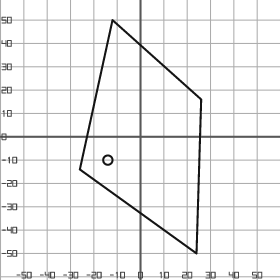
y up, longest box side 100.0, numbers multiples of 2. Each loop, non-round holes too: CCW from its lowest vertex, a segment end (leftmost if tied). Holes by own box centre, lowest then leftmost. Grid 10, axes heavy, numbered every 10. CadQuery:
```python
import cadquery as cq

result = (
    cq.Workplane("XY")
    .moveTo(24.0, -50.0)
    .lineTo(26.0, 16.0)
    .lineTo(-12.0, 50.0)
    .lineTo(-26.0, -14.0)
    .close()
    .moveTo(-14.0, -10.0)
    .circle(2.0)
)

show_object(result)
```